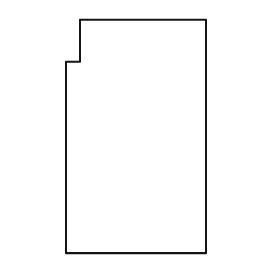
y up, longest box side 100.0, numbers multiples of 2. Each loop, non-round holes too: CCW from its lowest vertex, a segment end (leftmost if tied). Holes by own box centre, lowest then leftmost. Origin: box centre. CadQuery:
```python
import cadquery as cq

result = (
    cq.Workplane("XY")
    .moveTo(-30.0, -50.0)
    .lineTo(30.0, -50.0)
    .lineTo(30.0, 50.0)
    .lineTo(-24.0, 50.0)
    .lineTo(-24.0, 32.0)
    .lineTo(-30.0, 32.0)
    .close()
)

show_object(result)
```